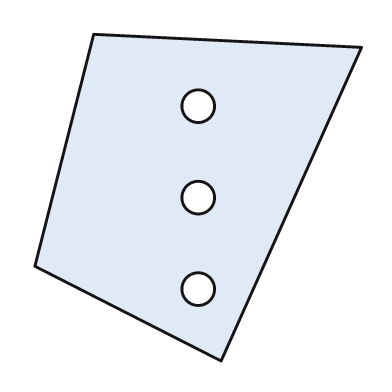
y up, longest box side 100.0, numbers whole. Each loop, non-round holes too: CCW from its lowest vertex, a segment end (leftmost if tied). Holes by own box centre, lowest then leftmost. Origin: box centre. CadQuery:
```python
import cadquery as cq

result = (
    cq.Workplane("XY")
    .moveTo(7.0, -50.0)
    .lineTo(50.0, 46.0)
    .lineTo(-32.0, 50.0)
    .lineTo(-50.0, -21.0)
    .close()
    .moveTo(0.0, -28.0)
    .circle(5.0)
    .moveTo(0.0, 0.0)
    .circle(5.0)
    .moveTo(0.0, 28.0)
    .circle(5.0)
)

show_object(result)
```